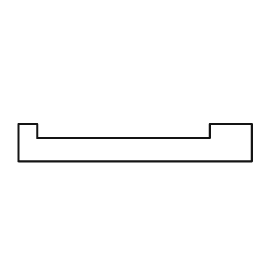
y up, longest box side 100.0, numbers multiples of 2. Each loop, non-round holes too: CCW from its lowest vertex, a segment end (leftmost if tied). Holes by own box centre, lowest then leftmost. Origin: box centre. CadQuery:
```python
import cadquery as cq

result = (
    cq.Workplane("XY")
    .moveTo(-50.0, -8.0)
    .lineTo(50.0, -8.0)
    .lineTo(50.0, 8.0)
    .lineTo(32.0, 8.0)
    .lineTo(32.0, 2.0)
    .lineTo(-42.0, 2.0)
    .lineTo(-42.0, 8.0)
    .lineTo(-50.0, 8.0)
    .close()
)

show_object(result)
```